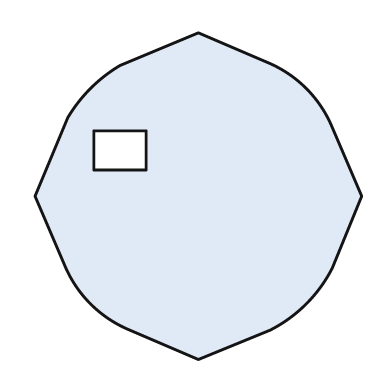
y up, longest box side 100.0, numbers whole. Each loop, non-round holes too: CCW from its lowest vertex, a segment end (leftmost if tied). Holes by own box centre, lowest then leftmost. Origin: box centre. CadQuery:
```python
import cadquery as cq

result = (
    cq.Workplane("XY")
    .moveTo(0.0, -50.0)
    .lineTo(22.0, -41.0)
    .threePointArc((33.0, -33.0), (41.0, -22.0))
    .lineTo(50.0, 0.0)
    .lineTo(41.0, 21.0)
    .threePointArc((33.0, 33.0), (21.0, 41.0))
    .lineTo(0.0, 50.0)
    .lineTo(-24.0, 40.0)
    .threePointArc((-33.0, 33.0), (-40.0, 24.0))
    .lineTo(-50.0, 0.0)
    .lineTo(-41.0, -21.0)
    .threePointArc((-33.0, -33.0), (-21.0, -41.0))
    .close()
    .moveTo(-32.0, 8.0)
    .lineTo(-16.0, 8.0)
    .lineTo(-16.0, 20.0)
    .lineTo(-32.0, 20.0)
    .close()
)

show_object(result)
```